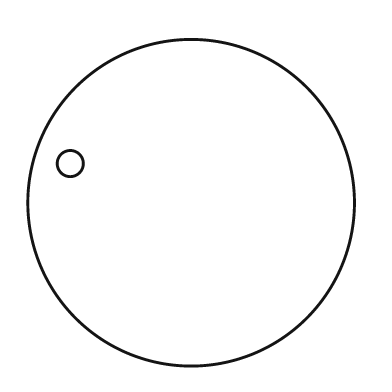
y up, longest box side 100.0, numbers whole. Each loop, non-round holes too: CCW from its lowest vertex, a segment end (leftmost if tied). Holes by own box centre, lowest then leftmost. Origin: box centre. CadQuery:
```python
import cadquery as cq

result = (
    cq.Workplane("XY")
    .moveTo(0.0, 0.0)
    .circle(50.0)
    .moveTo(-37.0, 12.0)
    .circle(4.0)
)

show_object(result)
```